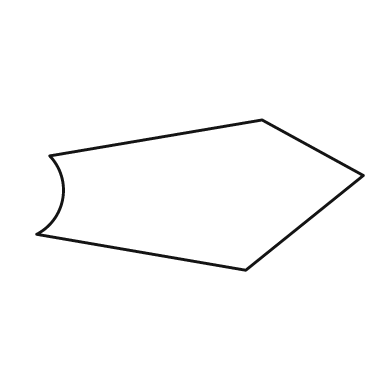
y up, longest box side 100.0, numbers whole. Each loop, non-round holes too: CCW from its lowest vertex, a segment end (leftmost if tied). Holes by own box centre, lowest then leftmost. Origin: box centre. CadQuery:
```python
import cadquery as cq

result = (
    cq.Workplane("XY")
    .moveTo(14.0, -23.0)
    .lineTo(50.0, 6.0)
    .lineTo(19.0, 23.0)
    .lineTo(-46.0, 12.0)
    .threePointArc((-42.0, -1.0), (-50.0, -12.0))
    .close()
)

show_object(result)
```